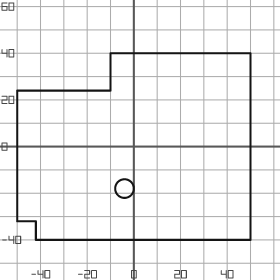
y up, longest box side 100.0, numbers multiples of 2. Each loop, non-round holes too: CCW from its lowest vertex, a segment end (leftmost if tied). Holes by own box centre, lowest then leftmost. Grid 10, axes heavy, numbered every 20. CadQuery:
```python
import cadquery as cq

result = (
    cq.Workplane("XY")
    .moveTo(-42.0, -40.0)
    .lineTo(50.0, -40.0)
    .lineTo(50.0, 40.0)
    .lineTo(-10.0, 40.0)
    .lineTo(-10.0, 24.0)
    .lineTo(-50.0, 24.0)
    .lineTo(-50.0, -32.0)
    .lineTo(-42.0, -32.0)
    .close()
    .moveTo(-4.0, -18.0)
    .circle(4.0)
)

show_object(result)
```